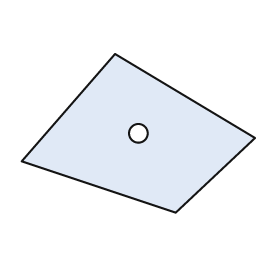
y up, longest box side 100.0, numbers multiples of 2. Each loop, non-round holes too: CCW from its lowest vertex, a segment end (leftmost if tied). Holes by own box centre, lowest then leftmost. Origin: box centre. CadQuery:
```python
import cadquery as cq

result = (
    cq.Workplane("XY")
    .moveTo(16.0, -34.0)
    .lineTo(50.0, -2.0)
    .lineTo(-10.0, 34.0)
    .lineTo(-50.0, -12.0)
    .close()
    .moveTo(0.0, 0.0)
    .circle(4.0)
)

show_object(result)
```